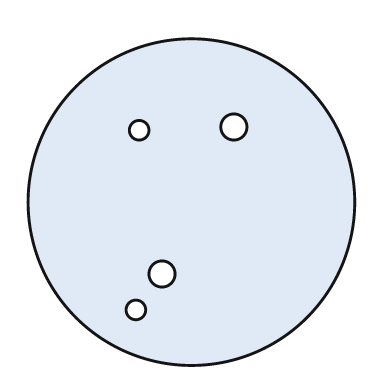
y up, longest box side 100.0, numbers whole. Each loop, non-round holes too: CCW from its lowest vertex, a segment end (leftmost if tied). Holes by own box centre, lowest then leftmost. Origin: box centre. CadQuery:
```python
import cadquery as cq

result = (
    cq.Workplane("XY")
    .moveTo(0.0, 0.0)
    .circle(50.0)
    .moveTo(-17.0, -33.0)
    .circle(3.0)
    .moveTo(-9.0, -22.0)
    .circle(4.0)
    .moveTo(-16.0, 22.0)
    .circle(3.0)
    .moveTo(13.0, 23.0)
    .circle(4.0)
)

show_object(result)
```